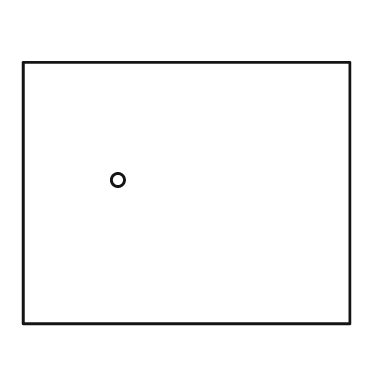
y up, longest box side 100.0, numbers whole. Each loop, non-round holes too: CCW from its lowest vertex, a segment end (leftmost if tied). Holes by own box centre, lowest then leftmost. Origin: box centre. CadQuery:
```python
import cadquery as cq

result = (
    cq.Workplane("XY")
    .moveTo(-50.0, -40.0)
    .lineTo(50.0, -40.0)
    .lineTo(50.0, 40.0)
    .lineTo(-50.0, 40.0)
    .close()
    .moveTo(-21.0, 4.0)
    .circle(2.0)
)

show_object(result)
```